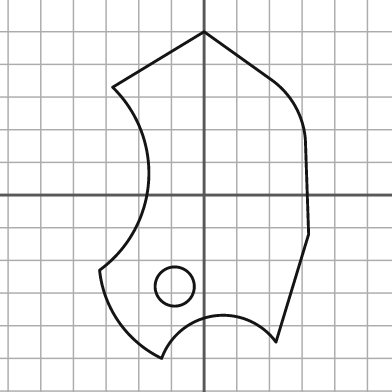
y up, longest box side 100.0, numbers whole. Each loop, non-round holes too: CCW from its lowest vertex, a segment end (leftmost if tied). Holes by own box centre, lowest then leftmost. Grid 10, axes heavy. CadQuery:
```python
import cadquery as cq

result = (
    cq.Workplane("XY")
    .moveTo(-13.0, -50.0)
    .threePointArc((3.0, -37.0), (22.0, -45.0))
    .lineTo(32.0, -12.0)
    .lineTo(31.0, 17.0)
    .threePointArc((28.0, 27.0), (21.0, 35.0))
    .lineTo(0.0, 50.0)
    .lineTo(-28.0, 33.0)
    .threePointArc((-17.0, 4.0), (-32.0, -23.0))
    .threePointArc((-26.0, -39.0), (-13.0, -50.0))
    .close()
    .moveTo(-9.0, -28.0)
    .circle(6.0)
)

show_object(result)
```